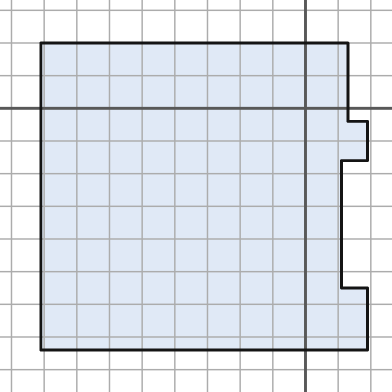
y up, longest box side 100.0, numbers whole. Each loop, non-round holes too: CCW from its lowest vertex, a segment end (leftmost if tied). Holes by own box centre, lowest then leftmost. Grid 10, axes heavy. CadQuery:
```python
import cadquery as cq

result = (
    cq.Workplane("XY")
    .moveTo(-81.0, -74.0)
    .lineTo(19.0, -74.0)
    .lineTo(19.0, -55.0)
    .lineTo(11.0, -55.0)
    .lineTo(11.0, -16.0)
    .lineTo(19.0, -16.0)
    .lineTo(19.0, -4.0)
    .lineTo(13.0, -4.0)
    .lineTo(13.0, 20.0)
    .lineTo(-81.0, 20.0)
    .close()
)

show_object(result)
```